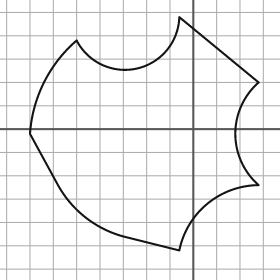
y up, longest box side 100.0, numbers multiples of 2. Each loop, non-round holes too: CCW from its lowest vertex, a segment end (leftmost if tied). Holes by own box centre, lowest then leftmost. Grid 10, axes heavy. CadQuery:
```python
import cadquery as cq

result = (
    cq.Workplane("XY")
    .moveTo(-6.0, -52.0)
    .threePointArc((6.0, -32.0), (28.0, -24.0))
    .threePointArc((18.0, -2.0), (28.0, 20.0))
    .lineTo(-6.0, 48.0)
    .threePointArc((-24.0, 26.0), (-50.0, 38.0))
    .threePointArc((-64.0, 20.0), (-70.0, -2.0))
    .lineTo(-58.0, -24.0)
    .threePointArc((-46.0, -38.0), (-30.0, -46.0))
    .close()
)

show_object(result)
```